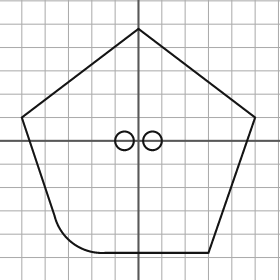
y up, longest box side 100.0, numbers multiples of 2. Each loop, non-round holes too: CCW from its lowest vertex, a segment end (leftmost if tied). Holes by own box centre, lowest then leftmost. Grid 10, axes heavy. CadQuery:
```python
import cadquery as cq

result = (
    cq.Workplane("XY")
    .moveTo(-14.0, -48.0)
    .lineTo(30.0, -48.0)
    .lineTo(50.0, 10.0)
    .lineTo(0.0, 48.0)
    .lineTo(-50.0, 10.0)
    .lineTo(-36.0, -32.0)
    .threePointArc((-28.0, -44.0), (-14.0, -48.0))
    .close()
    .moveTo(-6.0, 0.0)
    .circle(4.0)
    .moveTo(6.0, 0.0)
    .circle(4.0)
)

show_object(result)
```